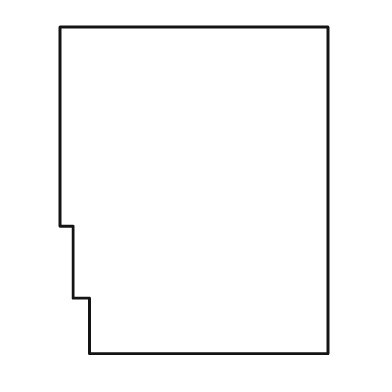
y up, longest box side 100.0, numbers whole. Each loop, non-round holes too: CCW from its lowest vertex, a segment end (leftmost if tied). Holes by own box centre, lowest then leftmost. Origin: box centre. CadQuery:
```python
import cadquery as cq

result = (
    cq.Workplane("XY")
    .moveTo(-32.0, -50.0)
    .lineTo(41.0, -50.0)
    .lineTo(41.0, 50.0)
    .lineTo(-41.0, 50.0)
    .lineTo(-41.0, -11.0)
    .lineTo(-37.0, -11.0)
    .lineTo(-37.0, -33.0)
    .lineTo(-32.0, -33.0)
    .close()
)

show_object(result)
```